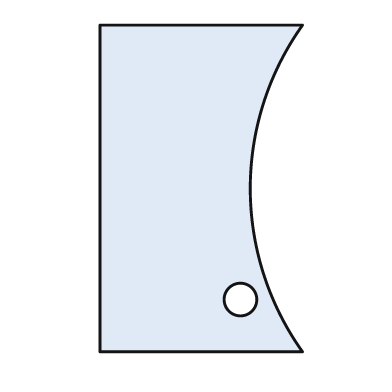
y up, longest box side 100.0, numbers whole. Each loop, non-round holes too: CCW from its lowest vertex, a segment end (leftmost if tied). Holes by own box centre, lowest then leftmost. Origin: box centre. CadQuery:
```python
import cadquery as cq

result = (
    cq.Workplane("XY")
    .moveTo(-31.0, -50.0)
    .lineTo(31.0, -50.0)
    .threePointArc((15.0, 0.0), (31.0, 50.0))
    .lineTo(-31.0, 50.0)
    .close()
    .moveTo(12.0, -34.0)
    .circle(5.0)
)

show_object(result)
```